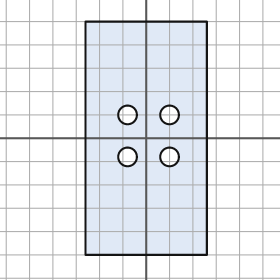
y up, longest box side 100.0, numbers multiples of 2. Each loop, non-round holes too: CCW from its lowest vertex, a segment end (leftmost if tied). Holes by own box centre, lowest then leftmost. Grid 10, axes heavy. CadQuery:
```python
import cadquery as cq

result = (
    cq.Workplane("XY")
    .moveTo(-26.0, -50.0)
    .lineTo(26.0, -50.0)
    .lineTo(26.0, 50.0)
    .lineTo(-26.0, 50.0)
    .close()
    .moveTo(-8.0, -8.0)
    .circle(4.0)
    .moveTo(10.0, -8.0)
    .circle(4.0)
    .moveTo(-8.0, 10.0)
    .circle(4.0)
    .moveTo(10.0, 10.0)
    .circle(4.0)
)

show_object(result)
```